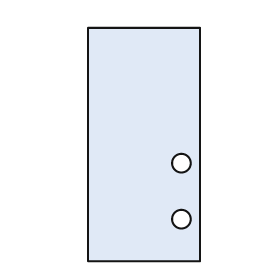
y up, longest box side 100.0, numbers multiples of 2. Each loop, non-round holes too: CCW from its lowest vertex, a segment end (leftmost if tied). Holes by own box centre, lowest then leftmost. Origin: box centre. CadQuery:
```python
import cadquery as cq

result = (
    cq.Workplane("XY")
    .moveTo(-24.0, -50.0)
    .lineTo(24.0, -50.0)
    .lineTo(24.0, 50.0)
    .lineTo(-24.0, 50.0)
    .close()
    .moveTo(16.0, -32.0)
    .circle(4.0)
    .moveTo(16.0, -8.0)
    .circle(4.0)
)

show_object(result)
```